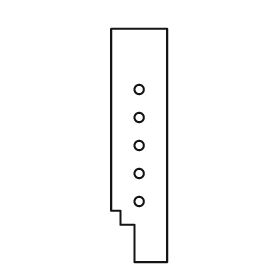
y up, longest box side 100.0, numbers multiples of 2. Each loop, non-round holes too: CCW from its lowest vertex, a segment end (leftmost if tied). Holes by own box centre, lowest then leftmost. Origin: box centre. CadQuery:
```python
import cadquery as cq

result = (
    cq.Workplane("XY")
    .moveTo(-2.0, -50.0)
    .lineTo(12.0, -50.0)
    .lineTo(12.0, 50.0)
    .lineTo(-12.0, 50.0)
    .lineTo(-12.0, -28.0)
    .lineTo(-8.0, -28.0)
    .lineTo(-8.0, -34.0)
    .lineTo(-2.0, -34.0)
    .close()
    .moveTo(0.0, -24.0)
    .circle(2.0)
    .moveTo(0.0, -12.0)
    .circle(2.0)
    .moveTo(0.0, 0.0)
    .circle(2.0)
    .moveTo(0.0, 12.0)
    .circle(2.0)
    .moveTo(0.0, 24.0)
    .circle(2.0)
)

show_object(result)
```